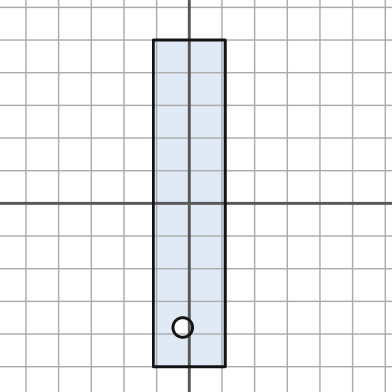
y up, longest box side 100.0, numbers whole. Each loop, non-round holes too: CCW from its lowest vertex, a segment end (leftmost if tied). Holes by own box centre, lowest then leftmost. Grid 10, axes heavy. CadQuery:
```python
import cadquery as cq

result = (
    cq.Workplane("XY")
    .moveTo(-11.0, -50.0)
    .lineTo(11.0, -50.0)
    .lineTo(11.0, 50.0)
    .lineTo(-11.0, 50.0)
    .close()
    .moveTo(-2.0, -38.0)
    .circle(3.0)
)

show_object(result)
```